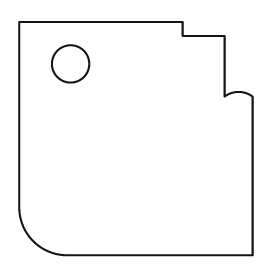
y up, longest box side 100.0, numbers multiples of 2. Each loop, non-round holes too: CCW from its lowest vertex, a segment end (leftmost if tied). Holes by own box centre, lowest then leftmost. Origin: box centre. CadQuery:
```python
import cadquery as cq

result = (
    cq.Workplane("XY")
    .moveTo(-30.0, -50.0)
    .lineTo(50.0, -50.0)
    .lineTo(50.0, 18.0)
    .threePointArc((44.0, 20.0), (38.0, 18.0))
    .lineTo(38.0, 44.0)
    .lineTo(20.0, 44.0)
    .lineTo(20.0, 50.0)
    .lineTo(-50.0, 50.0)
    .lineTo(-50.0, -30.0)
    .threePointArc((-44.0, -44.0), (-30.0, -50.0))
    .close()
    .moveTo(-28.0, 32.0)
    .circle(8.0)
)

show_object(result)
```